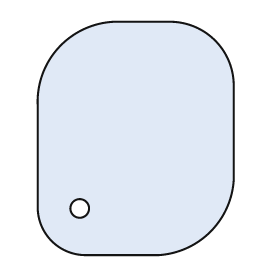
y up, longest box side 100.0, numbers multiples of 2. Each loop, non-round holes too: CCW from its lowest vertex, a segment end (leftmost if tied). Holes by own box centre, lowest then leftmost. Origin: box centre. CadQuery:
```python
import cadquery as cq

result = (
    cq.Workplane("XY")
    .moveTo(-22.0, -50.0)
    .lineTo(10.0, -50.0)
    .threePointArc((32.0, -40.0), (42.0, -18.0))
    .lineTo(42.0, 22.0)
    .threePointArc((34.0, 42.0), (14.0, 50.0))
    .lineTo(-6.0, 50.0)
    .threePointArc((-32.0, 40.0), (-42.0, 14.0))
    .lineTo(-42.0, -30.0)
    .threePointArc((-36.0, -44.0), (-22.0, -50.0))
    .close()
    .moveTo(-24.0, -30.0)
    .circle(4.0)
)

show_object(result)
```